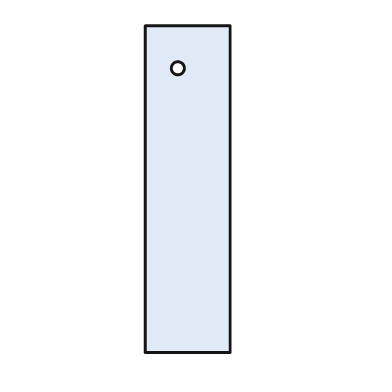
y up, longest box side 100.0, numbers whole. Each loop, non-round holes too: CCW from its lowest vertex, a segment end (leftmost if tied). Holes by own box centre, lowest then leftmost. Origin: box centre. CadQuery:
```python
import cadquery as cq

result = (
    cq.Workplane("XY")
    .moveTo(-13.0, -50.0)
    .lineTo(13.0, -50.0)
    .lineTo(13.0, 50.0)
    .lineTo(-13.0, 50.0)
    .close()
    .moveTo(-3.0, 37.0)
    .circle(2.0)
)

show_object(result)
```